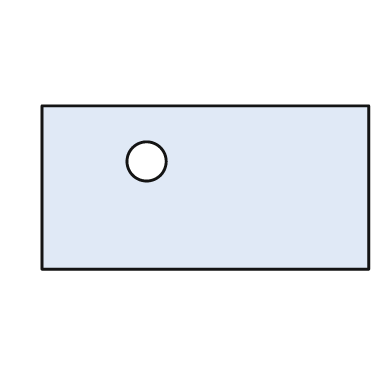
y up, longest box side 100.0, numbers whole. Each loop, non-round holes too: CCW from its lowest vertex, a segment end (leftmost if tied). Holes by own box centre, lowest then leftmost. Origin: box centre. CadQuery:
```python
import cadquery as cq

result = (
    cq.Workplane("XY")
    .moveTo(-50.0, -25.0)
    .lineTo(50.0, -25.0)
    .lineTo(50.0, 25.0)
    .lineTo(-50.0, 25.0)
    .close()
    .moveTo(-18.0, 8.0)
    .circle(6.0)
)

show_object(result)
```